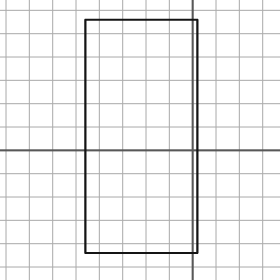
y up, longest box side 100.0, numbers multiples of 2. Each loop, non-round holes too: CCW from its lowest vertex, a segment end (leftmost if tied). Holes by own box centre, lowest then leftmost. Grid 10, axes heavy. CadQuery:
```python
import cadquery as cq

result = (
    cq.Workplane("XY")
    .moveTo(-46.0, -44.0)
    .lineTo(2.0, -44.0)
    .lineTo(2.0, 56.0)
    .lineTo(-46.0, 56.0)
    .close()
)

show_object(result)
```